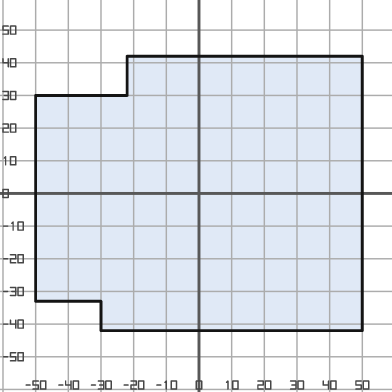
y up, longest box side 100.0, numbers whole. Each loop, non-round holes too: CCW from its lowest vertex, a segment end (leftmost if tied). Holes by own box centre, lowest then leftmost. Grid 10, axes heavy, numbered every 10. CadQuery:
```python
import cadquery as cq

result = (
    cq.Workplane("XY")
    .moveTo(-30.0, -42.0)
    .lineTo(50.0, -42.0)
    .lineTo(50.0, 42.0)
    .lineTo(-22.0, 42.0)
    .lineTo(-22.0, 30.0)
    .lineTo(-50.0, 30.0)
    .lineTo(-50.0, -33.0)
    .lineTo(-30.0, -33.0)
    .close()
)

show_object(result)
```